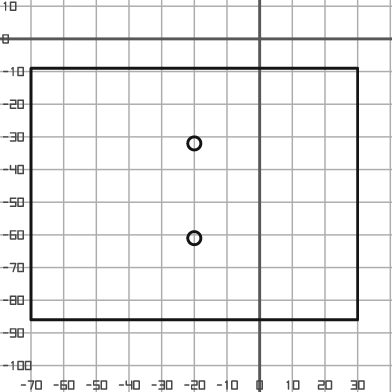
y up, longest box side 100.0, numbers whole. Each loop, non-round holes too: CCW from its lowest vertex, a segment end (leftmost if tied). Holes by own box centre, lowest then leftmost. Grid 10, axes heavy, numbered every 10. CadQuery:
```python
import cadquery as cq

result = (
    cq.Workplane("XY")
    .moveTo(-70.0, -86.0)
    .lineTo(30.0, -86.0)
    .lineTo(30.0, -9.0)
    .lineTo(-70.0, -9.0)
    .close()
    .moveTo(-20.0, -61.0)
    .circle(2.0)
    .moveTo(-20.0, -32.0)
    .circle(2.0)
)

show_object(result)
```